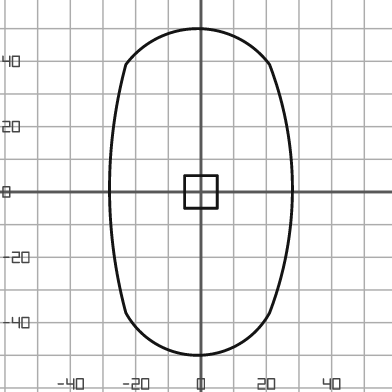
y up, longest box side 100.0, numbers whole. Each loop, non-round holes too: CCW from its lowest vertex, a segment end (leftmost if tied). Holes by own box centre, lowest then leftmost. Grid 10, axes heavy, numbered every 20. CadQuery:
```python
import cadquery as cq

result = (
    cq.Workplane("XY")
    .moveTo(-23.0, -37.0)
    .threePointArc((-1.0, -50.0), (21.0, -37.0))
    .threePointArc((28.0, 1.0), (21.0, 39.0))
    .threePointArc((-1.0, 50.0), (-23.0, 39.0))
    .threePointArc((-28.0, 1.0), (-23.0, -37.0))
    .close()
    .moveTo(-5.0, -5.0)
    .lineTo(5.0, -5.0)
    .lineTo(5.0, 5.0)
    .lineTo(-5.0, 5.0)
    .close()
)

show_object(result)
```